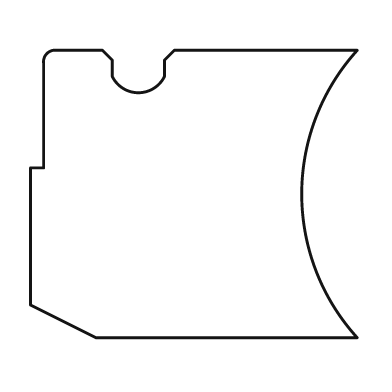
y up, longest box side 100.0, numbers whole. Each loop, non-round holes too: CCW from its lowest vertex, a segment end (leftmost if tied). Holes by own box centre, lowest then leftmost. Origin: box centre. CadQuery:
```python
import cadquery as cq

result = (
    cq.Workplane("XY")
    .moveTo(-30.0, -44.0)
    .lineTo(50.0, -44.0)
    .threePointArc((33.0, 0.0), (50.0, 44.0))
    .lineTo(-6.0, 44.0)
    .lineTo(-9.0, 41.0)
    .lineTo(-9.0, 36.0)
    .threePointArc((-17.0, 31.0), (-25.0, 36.0))
    .lineTo(-25.0, 41.0)
    .lineTo(-28.0, 44.0)
    .lineTo(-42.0, 44.0)
    .threePointArc((-45.0, 43.0), (-46.0, 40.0))
    .lineTo(-46.0, 8.0)
    .lineTo(-50.0, 8.0)
    .lineTo(-50.0, -34.0)
    .close()
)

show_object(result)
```